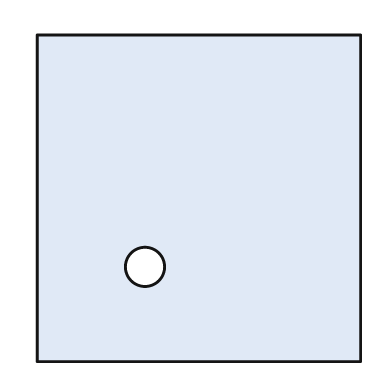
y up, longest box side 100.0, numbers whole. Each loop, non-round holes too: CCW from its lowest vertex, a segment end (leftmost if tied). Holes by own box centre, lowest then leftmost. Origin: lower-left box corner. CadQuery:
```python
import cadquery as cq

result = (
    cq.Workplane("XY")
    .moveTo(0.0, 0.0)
    .lineTo(99.0, 0.0)
    .lineTo(99.0, 100.0)
    .lineTo(0.0, 100.0)
    .close()
    .moveTo(33.0, 29.0)
    .circle(6.0)
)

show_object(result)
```